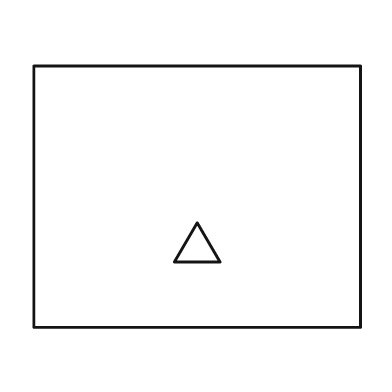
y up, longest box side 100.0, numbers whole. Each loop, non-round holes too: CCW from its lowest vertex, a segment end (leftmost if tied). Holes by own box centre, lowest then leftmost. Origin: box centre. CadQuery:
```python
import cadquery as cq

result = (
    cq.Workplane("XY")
    .moveTo(-50.0, -40.0)
    .lineTo(50.0, -40.0)
    .lineTo(50.0, 40.0)
    .lineTo(-50.0, 40.0)
    .close()
    .moveTo(-7.0, -20.0)
    .lineTo(7.0, -20.0)
    .lineTo(0.0, -8.0)
    .close()
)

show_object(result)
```